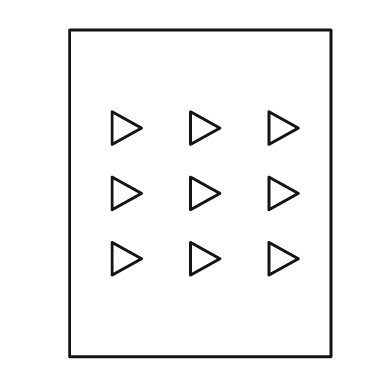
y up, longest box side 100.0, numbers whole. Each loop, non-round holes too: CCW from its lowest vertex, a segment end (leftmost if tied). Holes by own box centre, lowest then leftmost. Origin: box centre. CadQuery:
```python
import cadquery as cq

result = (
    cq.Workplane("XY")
    .moveTo(-40.0, -50.0)
    .lineTo(40.0, -50.0)
    .lineTo(40.0, 50.0)
    .lineTo(-40.0, 50.0)
    .close()
    .moveTo(-27.0, -25.0)
    .lineTo(-18.0, -20.0)
    .lineTo(-27.0, -15.0)
    .close()
    .moveTo(-3.0, -25.0)
    .lineTo(6.0, -20.0)
    .lineTo(-3.0, -15.0)
    .close()
    .moveTo(21.0, -25.0)
    .lineTo(30.0, -20.0)
    .lineTo(21.0, -15.0)
    .close()
    .moveTo(-27.0, -5.0)
    .lineTo(-18.0, 0.0)
    .lineTo(-27.0, 5.0)
    .close()
    .moveTo(-3.0, -5.0)
    .lineTo(6.0, 0.0)
    .lineTo(-3.0, 5.0)
    .close()
    .moveTo(21.0, -5.0)
    .lineTo(30.0, 0.0)
    .lineTo(21.0, 5.0)
    .close()
    .moveTo(-27.0, 15.0)
    .lineTo(-18.0, 20.0)
    .lineTo(-27.0, 25.0)
    .close()
    .moveTo(-3.0, 15.0)
    .lineTo(6.0, 20.0)
    .lineTo(-3.0, 25.0)
    .close()
    .moveTo(21.0, 15.0)
    .lineTo(30.0, 20.0)
    .lineTo(21.0, 25.0)
    .close()
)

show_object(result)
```